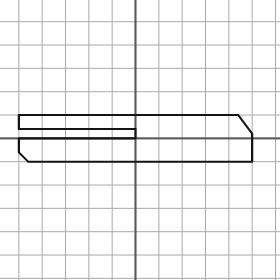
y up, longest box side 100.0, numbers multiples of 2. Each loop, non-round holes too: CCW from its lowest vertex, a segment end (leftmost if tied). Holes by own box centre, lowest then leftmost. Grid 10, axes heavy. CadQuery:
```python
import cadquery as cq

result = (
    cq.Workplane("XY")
    .moveTo(-46.0, -10.0)
    .lineTo(50.0, -10.0)
    .lineTo(50.0, 2.0)
    .lineTo(44.0, 10.0)
    .lineTo(-50.0, 10.0)
    .lineTo(-50.0, 4.0)
    .lineTo(0.0, 4.0)
    .lineTo(0.0, 0.0)
    .lineTo(-50.0, 0.0)
    .lineTo(-50.0, -6.0)
    .close()
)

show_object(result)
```